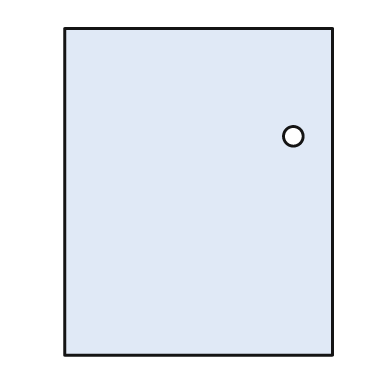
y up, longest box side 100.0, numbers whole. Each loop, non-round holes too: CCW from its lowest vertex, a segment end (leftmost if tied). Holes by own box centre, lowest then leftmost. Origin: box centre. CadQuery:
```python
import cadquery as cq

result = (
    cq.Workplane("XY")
    .moveTo(-41.0, -50.0)
    .lineTo(41.0, -50.0)
    .lineTo(41.0, 50.0)
    .lineTo(-41.0, 50.0)
    .close()
    .moveTo(29.0, 17.0)
    .circle(3.0)
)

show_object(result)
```